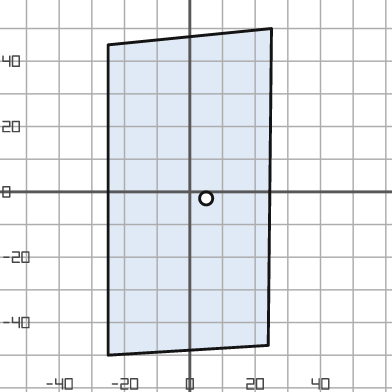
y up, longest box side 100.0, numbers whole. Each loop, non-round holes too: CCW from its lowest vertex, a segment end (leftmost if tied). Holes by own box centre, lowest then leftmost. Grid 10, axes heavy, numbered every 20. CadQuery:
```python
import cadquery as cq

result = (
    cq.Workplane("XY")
    .moveTo(-25.0, -50.0)
    .lineTo(24.0, -47.0)
    .lineTo(25.0, 50.0)
    .lineTo(-25.0, 45.0)
    .close()
    .moveTo(5.0, -2.0)
    .circle(2.0)
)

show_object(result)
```